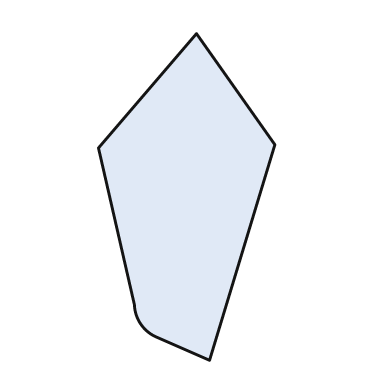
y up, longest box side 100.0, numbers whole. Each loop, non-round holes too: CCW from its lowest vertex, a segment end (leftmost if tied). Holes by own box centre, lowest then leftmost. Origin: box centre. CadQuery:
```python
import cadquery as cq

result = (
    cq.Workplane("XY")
    .moveTo(7.0, -50.0)
    .lineTo(27.0, 16.0)
    .lineTo(3.0, 50.0)
    .lineTo(-27.0, 15.0)
    .lineTo(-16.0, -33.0)
    .threePointArc((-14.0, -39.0), (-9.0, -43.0))
    .close()
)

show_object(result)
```